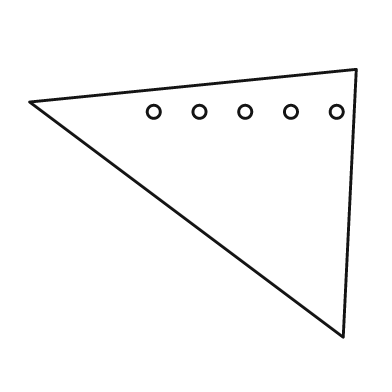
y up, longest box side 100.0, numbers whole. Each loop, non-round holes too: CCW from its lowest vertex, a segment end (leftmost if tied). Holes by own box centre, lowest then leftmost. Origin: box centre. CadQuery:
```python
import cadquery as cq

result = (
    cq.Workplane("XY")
    .moveTo(46.0, -41.0)
    .lineTo(50.0, 41.0)
    .lineTo(-50.0, 31.0)
    .close()
    .moveTo(-12.0, 28.0)
    .circle(2.0)
    .moveTo(2.0, 28.0)
    .circle(2.0)
    .moveTo(16.0, 28.0)
    .circle(2.0)
    .moveTo(30.0, 28.0)
    .circle(2.0)
    .moveTo(44.0, 28.0)
    .circle(2.0)
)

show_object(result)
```